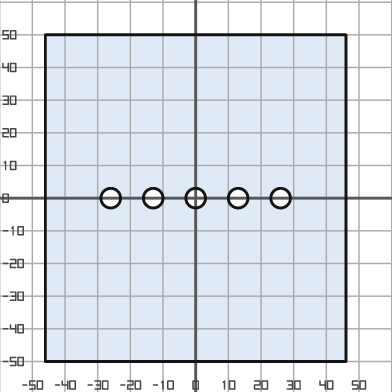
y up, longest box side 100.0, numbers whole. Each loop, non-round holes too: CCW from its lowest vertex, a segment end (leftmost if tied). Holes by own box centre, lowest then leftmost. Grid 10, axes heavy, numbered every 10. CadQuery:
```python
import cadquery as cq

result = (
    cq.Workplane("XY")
    .moveTo(-46.0, -50.0)
    .lineTo(46.0, -50.0)
    .lineTo(46.0, 50.0)
    .lineTo(-46.0, 50.0)
    .close()
    .moveTo(-26.0, 0.0)
    .circle(3.0)
    .moveTo(-13.0, 0.0)
    .circle(3.0)
    .moveTo(0.0, 0.0)
    .circle(3.0)
    .moveTo(13.0, 0.0)
    .circle(3.0)
    .moveTo(26.0, 0.0)
    .circle(3.0)
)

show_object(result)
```